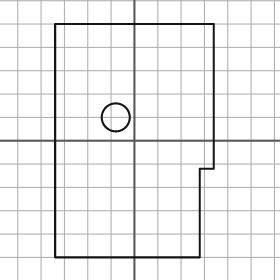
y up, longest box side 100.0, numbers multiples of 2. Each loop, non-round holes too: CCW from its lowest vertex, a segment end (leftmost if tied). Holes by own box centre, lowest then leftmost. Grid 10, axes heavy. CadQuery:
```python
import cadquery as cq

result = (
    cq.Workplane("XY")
    .moveTo(-34.0, -50.0)
    .lineTo(28.0, -50.0)
    .lineTo(28.0, -12.0)
    .lineTo(34.0, -12.0)
    .lineTo(34.0, 50.0)
    .lineTo(-34.0, 50.0)
    .close()
    .moveTo(-8.0, 10.0)
    .circle(6.0)
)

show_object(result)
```